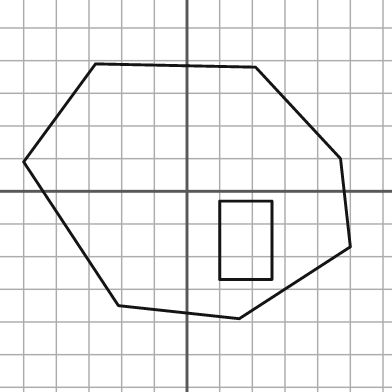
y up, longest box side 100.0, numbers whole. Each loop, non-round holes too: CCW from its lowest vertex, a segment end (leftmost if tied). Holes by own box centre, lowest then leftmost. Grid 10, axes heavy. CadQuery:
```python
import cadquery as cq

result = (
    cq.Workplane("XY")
    .moveTo(16.0, -39.0)
    .lineTo(50.0, -17.0)
    .lineTo(47.0, 10.0)
    .lineTo(21.0, 38.0)
    .lineTo(-28.0, 39.0)
    .lineTo(-50.0, 9.0)
    .lineTo(-21.0, -35.0)
    .close()
    .moveTo(10.0, -27.0)
    .lineTo(26.0, -27.0)
    .lineTo(26.0, -3.0)
    .lineTo(10.0, -3.0)
    .close()
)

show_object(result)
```